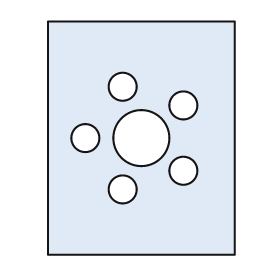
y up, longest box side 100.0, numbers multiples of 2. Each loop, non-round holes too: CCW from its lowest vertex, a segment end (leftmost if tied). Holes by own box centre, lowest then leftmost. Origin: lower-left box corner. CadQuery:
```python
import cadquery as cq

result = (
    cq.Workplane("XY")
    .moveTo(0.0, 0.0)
    .lineTo(80.0, 0.0)
    .lineTo(80.0, 100.0)
    .lineTo(0.0, 100.0)
    .close()
    .moveTo(32.0, 28.0)
    .circle(6.0)
    .moveTo(58.0, 36.0)
    .circle(6.0)
    .moveTo(16.0, 50.0)
    .circle(6.0)
    .moveTo(40.0, 50.0)
    .circle(12.0)
    .moveTo(58.0, 64.0)
    .circle(6.0)
    .moveTo(32.0, 72.0)
    .circle(6.0)
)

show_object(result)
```